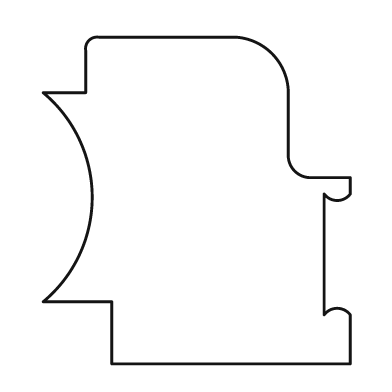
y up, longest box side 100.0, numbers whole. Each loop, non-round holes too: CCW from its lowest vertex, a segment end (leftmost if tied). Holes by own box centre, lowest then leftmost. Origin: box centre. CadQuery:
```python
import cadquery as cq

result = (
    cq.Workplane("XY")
    .moveTo(-26.0, -50.0)
    .lineTo(47.0, -50.0)
    .lineTo(47.0, -35.0)
    .threePointArc((43.0, -33.0), (39.0, -35.0))
    .lineTo(39.0, 2.0)
    .threePointArc((43.0, 0.0), (47.0, 2.0))
    .lineTo(47.0, 7.0)
    .lineTo(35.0, 7.0)
    .threePointArc((30.0, 9.0), (28.0, 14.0))
    .lineTo(28.0, 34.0)
    .threePointArc((23.0, 45.0), (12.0, 50.0))
    .lineTo(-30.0, 50.0)
    .threePointArc((-33.0, 49.0), (-34.0, 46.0))
    .lineTo(-34.0, 33.0)
    .lineTo(-47.0, 33.0)
    .threePointArc((-32.0, 1.0), (-47.0, -31.0))
    .lineTo(-26.0, -31.0)
    .close()
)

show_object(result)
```